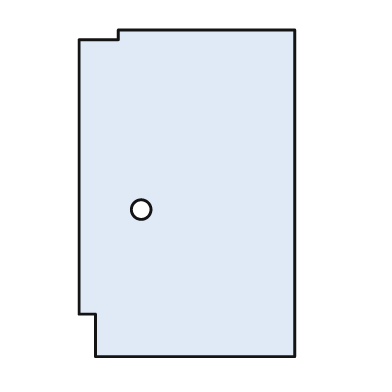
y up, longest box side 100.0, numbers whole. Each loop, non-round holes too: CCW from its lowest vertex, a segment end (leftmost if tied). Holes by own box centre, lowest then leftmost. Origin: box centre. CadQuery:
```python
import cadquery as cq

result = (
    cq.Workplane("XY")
    .moveTo(-28.0, -50.0)
    .lineTo(33.0, -50.0)
    .lineTo(33.0, 50.0)
    .lineTo(-21.0, 50.0)
    .lineTo(-21.0, 47.0)
    .lineTo(-33.0, 47.0)
    .lineTo(-33.0, -37.0)
    .lineTo(-28.0, -37.0)
    .close()
    .moveTo(-14.0, -5.0)
    .circle(3.0)
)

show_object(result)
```